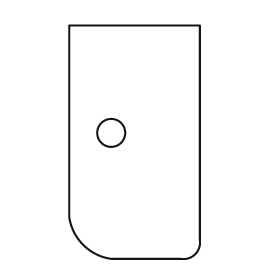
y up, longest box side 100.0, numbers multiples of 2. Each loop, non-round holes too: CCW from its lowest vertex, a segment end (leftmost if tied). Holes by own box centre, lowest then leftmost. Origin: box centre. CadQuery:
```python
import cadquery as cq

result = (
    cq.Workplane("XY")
    .moveTo(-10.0, -50.0)
    .lineTo(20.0, -50.0)
    .threePointArc((26.0, -48.0), (28.0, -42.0))
    .lineTo(28.0, 50.0)
    .lineTo(-28.0, 50.0)
    .lineTo(-28.0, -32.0)
    .threePointArc((-22.0, -44.0), (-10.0, -50.0))
    .close()
    .moveTo(-10.0, 4.0)
    .circle(6.0)
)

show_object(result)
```